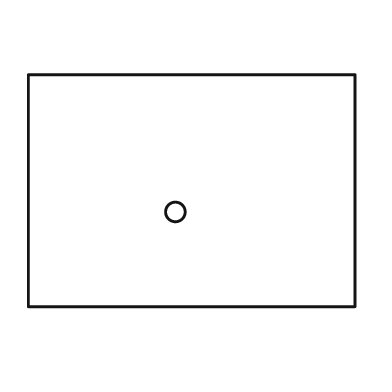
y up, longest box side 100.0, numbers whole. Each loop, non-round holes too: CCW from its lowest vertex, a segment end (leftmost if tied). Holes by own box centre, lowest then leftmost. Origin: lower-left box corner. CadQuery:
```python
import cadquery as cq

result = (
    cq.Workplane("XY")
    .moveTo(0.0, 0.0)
    .lineTo(100.0, 0.0)
    .lineTo(100.0, 71.0)
    .lineTo(0.0, 71.0)
    .close()
    .moveTo(45.0, 29.0)
    .circle(3.0)
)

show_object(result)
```